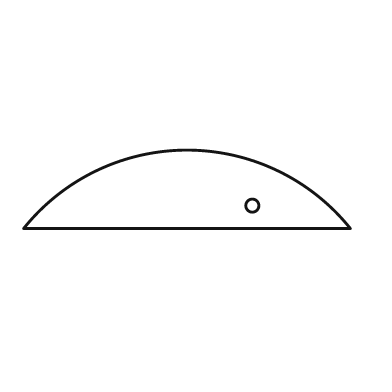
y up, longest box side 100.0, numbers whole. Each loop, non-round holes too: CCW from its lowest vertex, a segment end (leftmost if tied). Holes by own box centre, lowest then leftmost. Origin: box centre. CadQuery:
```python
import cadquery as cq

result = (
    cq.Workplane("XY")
    .moveTo(-50.0, -12.0)
    .lineTo(50.0, -12.0)
    .threePointArc((0.0, 12.0), (-50.0, -12.0))
    .close()
    .moveTo(20.0, -5.0)
    .circle(2.0)
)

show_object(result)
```